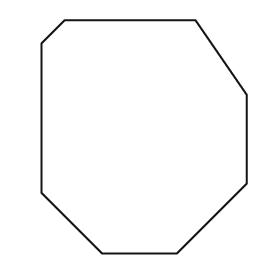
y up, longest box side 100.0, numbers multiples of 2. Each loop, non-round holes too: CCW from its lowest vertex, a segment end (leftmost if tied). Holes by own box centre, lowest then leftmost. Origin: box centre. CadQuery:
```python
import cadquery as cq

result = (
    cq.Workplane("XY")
    .moveTo(-18.0, -50.0)
    .lineTo(14.0, -50.0)
    .lineTo(44.0, -20.0)
    .lineTo(44.0, 18.0)
    .lineTo(22.0, 50.0)
    .lineTo(-34.0, 50.0)
    .lineTo(-44.0, 40.0)
    .lineTo(-44.0, -24.0)
    .close()
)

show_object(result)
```